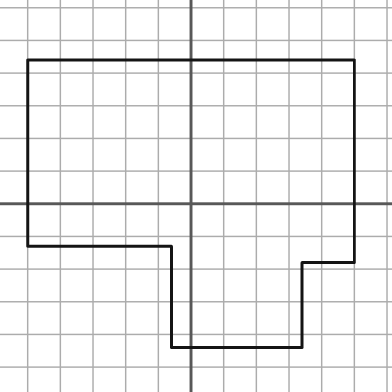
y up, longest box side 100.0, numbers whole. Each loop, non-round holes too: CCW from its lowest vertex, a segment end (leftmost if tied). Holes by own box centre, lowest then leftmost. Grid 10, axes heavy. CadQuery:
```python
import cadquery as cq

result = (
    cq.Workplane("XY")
    .moveTo(-6.0, -44.0)
    .lineTo(34.0, -44.0)
    .lineTo(34.0, -18.0)
    .lineTo(50.0, -18.0)
    .lineTo(50.0, 44.0)
    .lineTo(-50.0, 44.0)
    .lineTo(-50.0, -13.0)
    .lineTo(-6.0, -13.0)
    .close()
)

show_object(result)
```